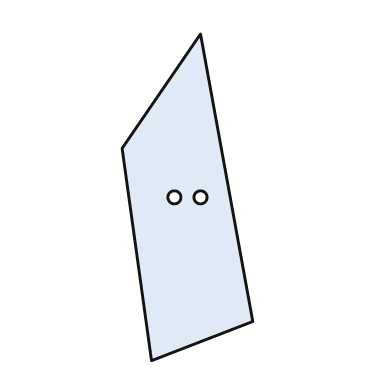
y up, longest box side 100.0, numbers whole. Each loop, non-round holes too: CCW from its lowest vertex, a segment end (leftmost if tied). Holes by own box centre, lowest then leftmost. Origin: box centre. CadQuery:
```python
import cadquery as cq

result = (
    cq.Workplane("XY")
    .moveTo(-11.0, -50.0)
    .lineTo(20.0, -38.0)
    .lineTo(4.0, 50.0)
    .lineTo(-20.0, 15.0)
    .close()
    .moveTo(-4.0, 0.0)
    .circle(2.0)
    .moveTo(4.0, 0.0)
    .circle(2.0)
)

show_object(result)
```